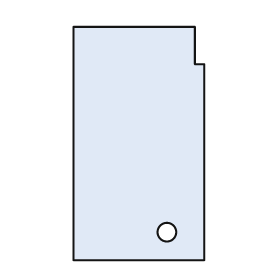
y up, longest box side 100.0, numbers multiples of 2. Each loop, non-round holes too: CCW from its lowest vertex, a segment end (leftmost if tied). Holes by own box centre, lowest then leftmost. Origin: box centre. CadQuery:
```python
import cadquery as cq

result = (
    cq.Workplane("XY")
    .moveTo(-28.0, -50.0)
    .lineTo(28.0, -50.0)
    .lineTo(28.0, 34.0)
    .lineTo(24.0, 34.0)
    .lineTo(24.0, 50.0)
    .lineTo(-28.0, 50.0)
    .close()
    .moveTo(12.0, -38.0)
    .circle(4.0)
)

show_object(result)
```